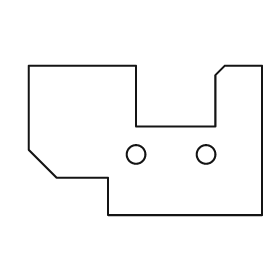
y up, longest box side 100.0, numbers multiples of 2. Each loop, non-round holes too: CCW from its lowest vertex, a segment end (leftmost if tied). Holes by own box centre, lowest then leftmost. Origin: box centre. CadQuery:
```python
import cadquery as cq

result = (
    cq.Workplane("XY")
    .moveTo(-16.0, -32.0)
    .lineTo(50.0, -32.0)
    .lineTo(50.0, 32.0)
    .lineTo(34.0, 32.0)
    .lineTo(30.0, 28.0)
    .lineTo(30.0, 6.0)
    .lineTo(-4.0, 6.0)
    .lineTo(-4.0, 32.0)
    .lineTo(-50.0, 32.0)
    .lineTo(-50.0, -4.0)
    .lineTo(-38.0, -16.0)
    .lineTo(-16.0, -16.0)
    .close()
    .moveTo(-4.0, -6.0)
    .circle(4.0)
    .moveTo(26.0, -6.0)
    .circle(4.0)
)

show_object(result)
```